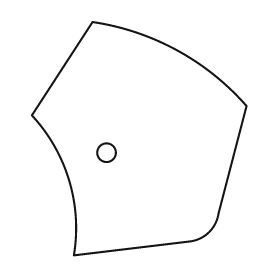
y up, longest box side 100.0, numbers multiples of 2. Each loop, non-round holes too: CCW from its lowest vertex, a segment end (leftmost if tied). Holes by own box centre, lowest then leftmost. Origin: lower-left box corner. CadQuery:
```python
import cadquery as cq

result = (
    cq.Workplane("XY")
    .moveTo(18.0, 0.0)
    .lineTo(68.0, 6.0)
    .threePointArc((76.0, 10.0), (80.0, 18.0))
    .lineTo(92.0, 64.0)
    .threePointArc((62.0, 88.0), (26.0, 100.0))
    .lineTo(0.0, 60.0)
    .threePointArc((16.0, 32.0), (18.0, 0.0))
    .close()
    .moveTo(32.0, 44.0)
    .circle(4.0)
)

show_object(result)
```